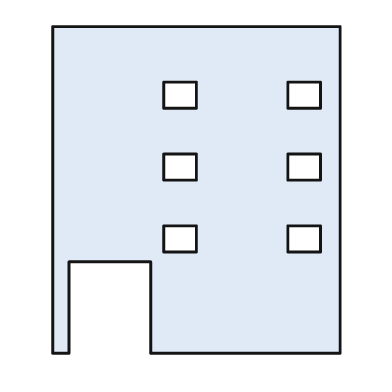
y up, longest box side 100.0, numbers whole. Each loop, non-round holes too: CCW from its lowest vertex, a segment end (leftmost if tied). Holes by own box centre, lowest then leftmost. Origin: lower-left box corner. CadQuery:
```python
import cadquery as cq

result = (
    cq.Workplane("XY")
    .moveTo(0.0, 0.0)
    .lineTo(5.0, 0.0)
    .lineTo(5.0, 28.0)
    .lineTo(30.0, 28.0)
    .lineTo(30.0, 0.0)
    .lineTo(88.0, 0.0)
    .lineTo(88.0, 100.0)
    .lineTo(0.0, 100.0)
    .close()
    .moveTo(34.0, 31.0)
    .lineTo(44.0, 31.0)
    .lineTo(44.0, 39.0)
    .lineTo(34.0, 39.0)
    .close()
    .moveTo(72.0, 31.0)
    .lineTo(82.0, 31.0)
    .lineTo(82.0, 39.0)
    .lineTo(72.0, 39.0)
    .close()
    .moveTo(34.0, 53.0)
    .lineTo(44.0, 53.0)
    .lineTo(44.0, 61.0)
    .lineTo(34.0, 61.0)
    .close()
    .moveTo(72.0, 53.0)
    .lineTo(82.0, 53.0)
    .lineTo(82.0, 61.0)
    .lineTo(72.0, 61.0)
    .close()
    .moveTo(34.0, 75.0)
    .lineTo(44.0, 75.0)
    .lineTo(44.0, 83.0)
    .lineTo(34.0, 83.0)
    .close()
    .moveTo(72.0, 75.0)
    .lineTo(82.0, 75.0)
    .lineTo(82.0, 83.0)
    .lineTo(72.0, 83.0)
    .close()
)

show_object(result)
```